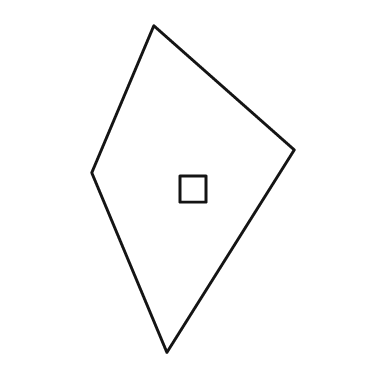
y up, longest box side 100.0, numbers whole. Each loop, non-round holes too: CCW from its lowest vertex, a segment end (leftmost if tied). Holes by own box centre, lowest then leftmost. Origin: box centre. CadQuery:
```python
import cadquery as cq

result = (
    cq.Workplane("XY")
    .moveTo(-8.0, -50.0)
    .lineTo(31.0, 12.0)
    .lineTo(-12.0, 50.0)
    .lineTo(-31.0, 5.0)
    .close()
    .moveTo(-4.0, -4.0)
    .lineTo(4.0, -4.0)
    .lineTo(4.0, 4.0)
    .lineTo(-4.0, 4.0)
    .close()
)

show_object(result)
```